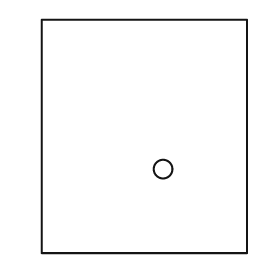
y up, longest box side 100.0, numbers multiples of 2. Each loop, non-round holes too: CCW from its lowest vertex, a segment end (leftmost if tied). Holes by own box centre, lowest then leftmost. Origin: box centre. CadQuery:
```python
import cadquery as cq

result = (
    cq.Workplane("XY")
    .moveTo(-44.0, -50.0)
    .lineTo(44.0, -50.0)
    .lineTo(44.0, 50.0)
    .lineTo(-44.0, 50.0)
    .close()
    .moveTo(8.0, -14.0)
    .circle(4.0)
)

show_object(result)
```